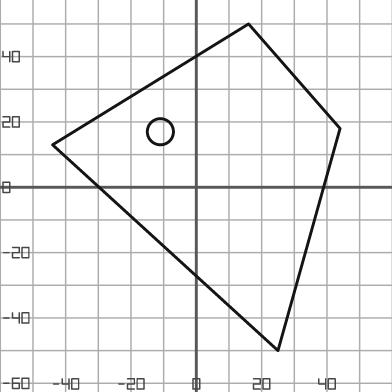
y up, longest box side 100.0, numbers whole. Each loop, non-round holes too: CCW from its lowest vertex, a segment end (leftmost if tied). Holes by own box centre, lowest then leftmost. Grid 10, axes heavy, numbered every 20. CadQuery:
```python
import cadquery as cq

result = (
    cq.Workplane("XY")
    .moveTo(25.0, -50.0)
    .lineTo(44.0, 18.0)
    .lineTo(16.0, 50.0)
    .lineTo(-44.0, 13.0)
    .close()
    .moveTo(-11.0, 17.0)
    .circle(4.0)
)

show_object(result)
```